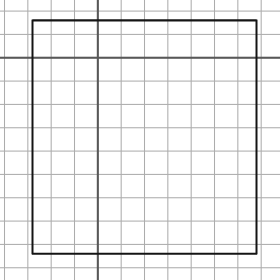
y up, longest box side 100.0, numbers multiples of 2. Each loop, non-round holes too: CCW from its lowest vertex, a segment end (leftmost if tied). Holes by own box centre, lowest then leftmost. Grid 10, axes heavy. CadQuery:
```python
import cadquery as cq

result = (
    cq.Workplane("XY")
    .moveTo(-28.0, -84.0)
    .lineTo(68.0, -84.0)
    .lineTo(68.0, 16.0)
    .lineTo(-28.0, 16.0)
    .close()
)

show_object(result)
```